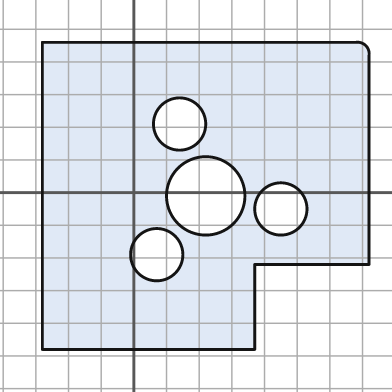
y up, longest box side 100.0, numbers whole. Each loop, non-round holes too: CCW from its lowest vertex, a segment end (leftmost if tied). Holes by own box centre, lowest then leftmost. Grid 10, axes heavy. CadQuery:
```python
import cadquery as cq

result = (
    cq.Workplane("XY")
    .moveTo(-28.0, -48.0)
    .lineTo(37.0, -48.0)
    .lineTo(37.0, -22.0)
    .lineTo(72.0, -22.0)
    .lineTo(72.0, 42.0)
    .threePointArc((71.0, 45.0), (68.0, 46.0))
    .lineTo(-28.0, 46.0)
    .close()
    .moveTo(7.0, -19.0)
    .circle(8.0)
    .moveTo(45.0, -5.0)
    .circle(8.0)
    .moveTo(22.0, -1.0)
    .circle(12.0)
    .moveTo(14.0, 21.0)
    .circle(8.0)
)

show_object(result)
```